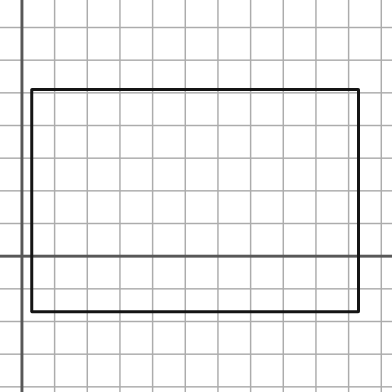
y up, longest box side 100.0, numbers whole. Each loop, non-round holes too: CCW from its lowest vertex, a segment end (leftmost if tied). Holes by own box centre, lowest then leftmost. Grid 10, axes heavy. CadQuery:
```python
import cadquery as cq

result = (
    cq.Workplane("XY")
    .moveTo(3.0, -17.0)
    .lineTo(103.0, -17.0)
    .lineTo(103.0, 51.0)
    .lineTo(3.0, 51.0)
    .close()
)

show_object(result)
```